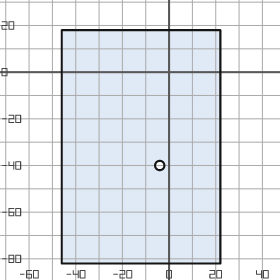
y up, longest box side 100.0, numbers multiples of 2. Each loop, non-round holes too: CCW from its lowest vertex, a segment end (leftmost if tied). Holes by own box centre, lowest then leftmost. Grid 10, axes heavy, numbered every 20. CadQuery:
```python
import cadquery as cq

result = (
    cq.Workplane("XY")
    .moveTo(-46.0, -82.0)
    .lineTo(22.0, -82.0)
    .lineTo(22.0, 18.0)
    .lineTo(-46.0, 18.0)
    .close()
    .moveTo(-4.0, -40.0)
    .circle(2.0)
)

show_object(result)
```